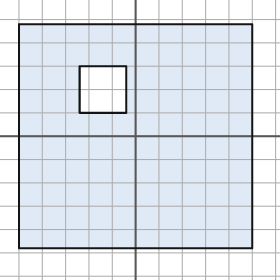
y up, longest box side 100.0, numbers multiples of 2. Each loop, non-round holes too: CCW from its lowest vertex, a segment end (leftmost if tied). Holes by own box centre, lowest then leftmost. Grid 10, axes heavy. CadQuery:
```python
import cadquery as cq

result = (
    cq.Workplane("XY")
    .moveTo(-50.0, -48.0)
    .lineTo(50.0, -48.0)
    .lineTo(50.0, 48.0)
    .lineTo(-50.0, 48.0)
    .close()
    .moveTo(-24.0, 10.0)
    .lineTo(-4.0, 10.0)
    .lineTo(-4.0, 30.0)
    .lineTo(-24.0, 30.0)
    .close()
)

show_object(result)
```